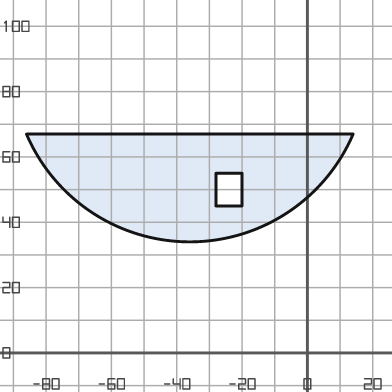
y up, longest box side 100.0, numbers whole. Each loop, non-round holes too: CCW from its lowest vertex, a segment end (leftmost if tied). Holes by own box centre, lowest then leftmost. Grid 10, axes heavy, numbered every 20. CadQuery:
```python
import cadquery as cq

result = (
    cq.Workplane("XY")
    .moveTo(-86.0, 67.0)
    .threePointArc((-36.0, 34.0), (14.0, 67.0))
    .close()
    .moveTo(-28.0, 45.0)
    .lineTo(-20.0, 45.0)
    .lineTo(-20.0, 55.0)
    .lineTo(-28.0, 55.0)
    .close()
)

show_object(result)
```